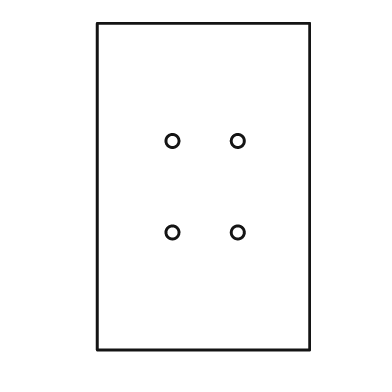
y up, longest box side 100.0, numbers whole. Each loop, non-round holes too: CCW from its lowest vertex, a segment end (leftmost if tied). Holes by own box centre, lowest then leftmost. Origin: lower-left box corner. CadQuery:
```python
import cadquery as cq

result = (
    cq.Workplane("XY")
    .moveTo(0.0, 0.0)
    .lineTo(65.0, 0.0)
    .lineTo(65.0, 100.0)
    .lineTo(0.0, 100.0)
    .close()
    .moveTo(23.0, 36.0)
    .circle(2.0)
    .moveTo(43.0, 36.0)
    .circle(2.0)
    .moveTo(23.0, 64.0)
    .circle(2.0)
    .moveTo(43.0, 64.0)
    .circle(2.0)
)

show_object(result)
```